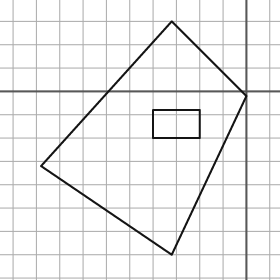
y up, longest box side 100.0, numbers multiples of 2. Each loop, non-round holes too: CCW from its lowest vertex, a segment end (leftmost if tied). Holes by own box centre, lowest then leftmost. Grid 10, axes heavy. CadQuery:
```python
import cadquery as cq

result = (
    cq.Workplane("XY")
    .moveTo(-32.0, -70.0)
    .lineTo(0.0, -2.0)
    .lineTo(-32.0, 30.0)
    .lineTo(-88.0, -32.0)
    .close()
    .moveTo(-40.0, -20.0)
    .lineTo(-20.0, -20.0)
    .lineTo(-20.0, -8.0)
    .lineTo(-40.0, -8.0)
    .close()
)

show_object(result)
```